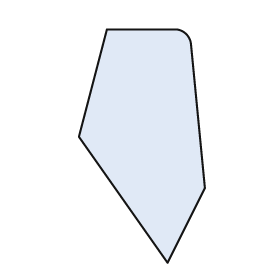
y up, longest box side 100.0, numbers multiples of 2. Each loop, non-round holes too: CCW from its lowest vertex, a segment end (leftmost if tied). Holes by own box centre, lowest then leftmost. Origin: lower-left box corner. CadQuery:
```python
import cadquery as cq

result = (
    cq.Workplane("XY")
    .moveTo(38.0, 0.0)
    .lineTo(54.0, 32.0)
    .lineTo(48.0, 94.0)
    .threePointArc((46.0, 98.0), (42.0, 100.0))
    .lineTo(12.0, 100.0)
    .lineTo(0.0, 54.0)
    .close()
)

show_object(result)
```